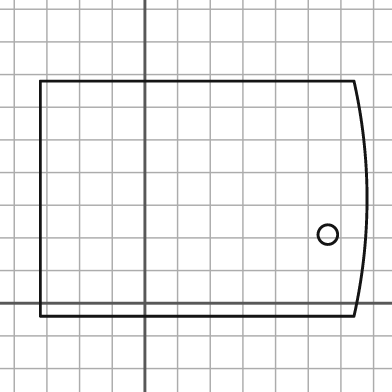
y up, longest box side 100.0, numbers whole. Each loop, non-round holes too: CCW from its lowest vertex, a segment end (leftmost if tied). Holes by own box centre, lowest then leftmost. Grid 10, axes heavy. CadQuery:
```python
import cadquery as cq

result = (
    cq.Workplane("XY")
    .moveTo(-32.0, -4.0)
    .lineTo(64.0, -4.0)
    .threePointArc((68.0, 32.0), (64.0, 68.0))
    .lineTo(-32.0, 68.0)
    .close()
    .moveTo(56.0, 21.0)
    .circle(3.0)
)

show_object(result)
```